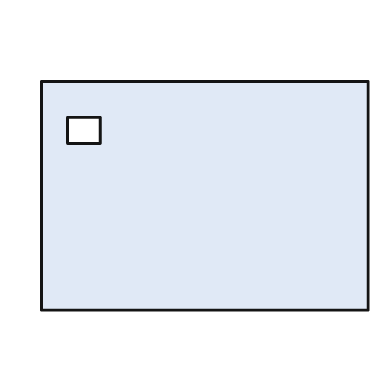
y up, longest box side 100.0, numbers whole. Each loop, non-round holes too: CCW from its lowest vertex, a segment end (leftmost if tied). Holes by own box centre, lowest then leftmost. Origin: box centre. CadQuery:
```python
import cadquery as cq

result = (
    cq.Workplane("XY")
    .moveTo(-50.0, -35.0)
    .lineTo(50.0, -35.0)
    .lineTo(50.0, 35.0)
    .lineTo(-50.0, 35.0)
    .close()
    .moveTo(-42.0, 16.0)
    .lineTo(-32.0, 16.0)
    .lineTo(-32.0, 24.0)
    .lineTo(-42.0, 24.0)
    .close()
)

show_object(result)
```